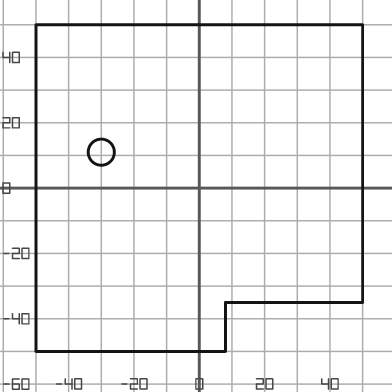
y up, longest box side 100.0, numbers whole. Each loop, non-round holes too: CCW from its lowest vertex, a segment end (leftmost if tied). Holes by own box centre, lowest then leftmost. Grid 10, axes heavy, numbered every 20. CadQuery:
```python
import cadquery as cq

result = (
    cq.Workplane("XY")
    .moveTo(-50.0, -50.0)
    .lineTo(8.0, -50.0)
    .lineTo(8.0, -35.0)
    .lineTo(50.0, -35.0)
    .lineTo(50.0, 50.0)
    .lineTo(-50.0, 50.0)
    .close()
    .moveTo(-30.0, 11.0)
    .circle(4.0)
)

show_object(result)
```